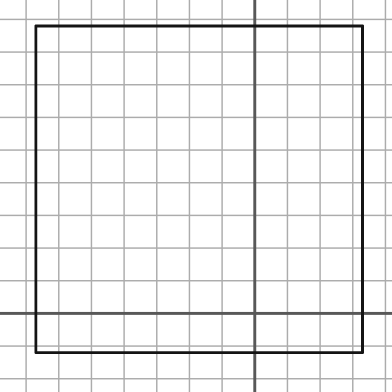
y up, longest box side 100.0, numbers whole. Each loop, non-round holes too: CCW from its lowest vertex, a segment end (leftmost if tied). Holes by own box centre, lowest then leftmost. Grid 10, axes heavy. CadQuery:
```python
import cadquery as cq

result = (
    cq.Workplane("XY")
    .moveTo(-67.0, -12.0)
    .lineTo(33.0, -12.0)
    .lineTo(33.0, 88.0)
    .lineTo(-67.0, 88.0)
    .close()
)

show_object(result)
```